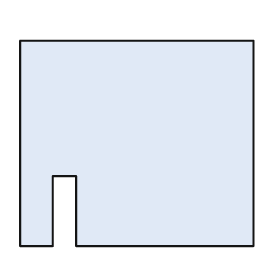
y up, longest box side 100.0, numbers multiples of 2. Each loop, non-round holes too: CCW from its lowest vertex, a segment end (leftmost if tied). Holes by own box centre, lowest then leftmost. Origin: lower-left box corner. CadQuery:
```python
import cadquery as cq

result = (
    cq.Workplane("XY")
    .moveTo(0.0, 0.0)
    .lineTo(14.0, 0.0)
    .lineTo(14.0, 30.0)
    .lineTo(24.0, 30.0)
    .lineTo(24.0, 0.0)
    .lineTo(100.0, 0.0)
    .lineTo(100.0, 88.0)
    .lineTo(0.0, 88.0)
    .close()
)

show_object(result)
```